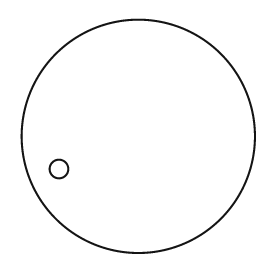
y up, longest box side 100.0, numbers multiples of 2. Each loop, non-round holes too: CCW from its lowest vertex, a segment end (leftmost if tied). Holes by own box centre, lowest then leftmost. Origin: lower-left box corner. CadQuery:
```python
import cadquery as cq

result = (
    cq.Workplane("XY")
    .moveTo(50.0, 50.0)
    .circle(50.0)
    .moveTo(16.0, 36.0)
    .circle(4.0)
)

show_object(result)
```